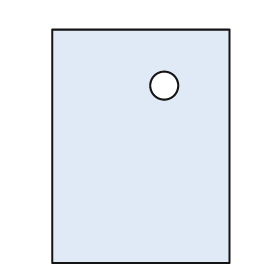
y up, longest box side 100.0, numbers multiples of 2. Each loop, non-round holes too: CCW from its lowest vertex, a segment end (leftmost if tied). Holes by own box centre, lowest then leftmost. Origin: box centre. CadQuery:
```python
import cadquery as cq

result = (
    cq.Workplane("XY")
    .moveTo(-38.0, -50.0)
    .lineTo(38.0, -50.0)
    .lineTo(38.0, 50.0)
    .lineTo(-38.0, 50.0)
    .close()
    .moveTo(10.0, 26.0)
    .circle(6.0)
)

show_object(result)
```